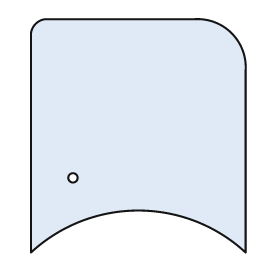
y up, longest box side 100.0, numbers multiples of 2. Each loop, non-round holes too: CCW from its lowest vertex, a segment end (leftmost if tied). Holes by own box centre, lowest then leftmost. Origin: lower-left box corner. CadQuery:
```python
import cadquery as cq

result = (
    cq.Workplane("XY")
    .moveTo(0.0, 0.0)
    .threePointArc((46.0, 18.0), (92.0, 0.0))
    .lineTo(92.0, 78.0)
    .threePointArc((86.0, 94.0), (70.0, 100.0))
    .lineTo(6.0, 100.0)
    .threePointArc((2.0, 98.0), (0.0, 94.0))
    .close()
    .moveTo(18.0, 32.0)
    .circle(2.0)
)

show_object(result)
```